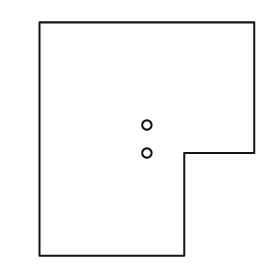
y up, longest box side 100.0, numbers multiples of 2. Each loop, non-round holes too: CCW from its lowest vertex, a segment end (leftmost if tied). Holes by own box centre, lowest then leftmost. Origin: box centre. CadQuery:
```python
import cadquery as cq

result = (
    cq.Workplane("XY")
    .moveTo(-46.0, -50.0)
    .lineTo(16.0, -50.0)
    .lineTo(16.0, -6.0)
    .lineTo(46.0, -6.0)
    .lineTo(46.0, 50.0)
    .lineTo(-46.0, 50.0)
    .close()
    .moveTo(0.0, -6.0)
    .circle(2.0)
    .moveTo(0.0, 6.0)
    .circle(2.0)
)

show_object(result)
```